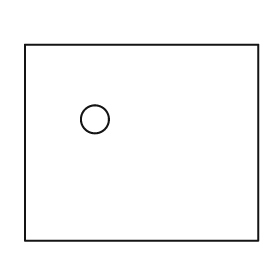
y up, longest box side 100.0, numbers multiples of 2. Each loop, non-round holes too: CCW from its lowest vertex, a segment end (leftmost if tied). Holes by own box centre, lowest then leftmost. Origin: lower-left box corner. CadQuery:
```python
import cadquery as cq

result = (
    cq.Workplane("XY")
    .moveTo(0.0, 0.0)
    .lineTo(100.0, 0.0)
    .lineTo(100.0, 84.0)
    .lineTo(0.0, 84.0)
    .close()
    .moveTo(30.0, 52.0)
    .circle(6.0)
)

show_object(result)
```